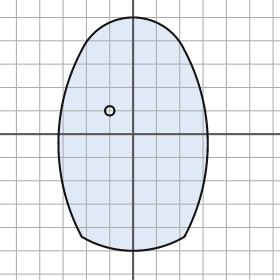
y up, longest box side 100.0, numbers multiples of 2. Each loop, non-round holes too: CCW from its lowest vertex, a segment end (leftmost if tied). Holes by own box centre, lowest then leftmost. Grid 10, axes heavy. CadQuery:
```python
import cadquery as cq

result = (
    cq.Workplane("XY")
    .moveTo(-22.0, -44.0)
    .threePointArc((0.0, -50.0), (22.0, -44.0))
    .threePointArc((32.0, -4.0), (22.0, 36.0))
    .threePointArc((0.0, 50.0), (-22.0, 36.0))
    .threePointArc((-32.0, -4.0), (-22.0, -44.0))
    .close()
    .moveTo(-10.0, 10.0)
    .circle(2.0)
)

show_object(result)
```